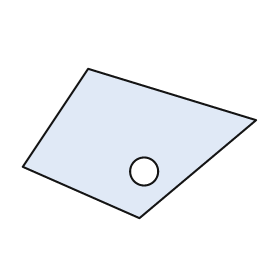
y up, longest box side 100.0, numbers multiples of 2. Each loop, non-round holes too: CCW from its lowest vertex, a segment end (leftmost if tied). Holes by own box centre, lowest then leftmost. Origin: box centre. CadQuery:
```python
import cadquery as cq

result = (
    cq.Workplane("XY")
    .moveTo(0.0, -32.0)
    .lineTo(50.0, 10.0)
    .lineTo(-22.0, 32.0)
    .lineTo(-50.0, -10.0)
    .close()
    .moveTo(2.0, -12.0)
    .circle(6.0)
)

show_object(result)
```